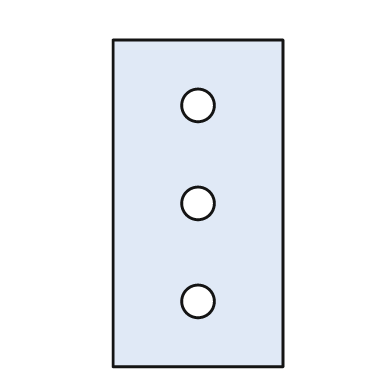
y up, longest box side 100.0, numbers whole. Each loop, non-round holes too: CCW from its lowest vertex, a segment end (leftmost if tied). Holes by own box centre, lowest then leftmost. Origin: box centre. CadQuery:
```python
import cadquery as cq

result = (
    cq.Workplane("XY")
    .moveTo(-26.0, -50.0)
    .lineTo(26.0, -50.0)
    .lineTo(26.0, 50.0)
    .lineTo(-26.0, 50.0)
    .close()
    .moveTo(0.0, -30.0)
    .circle(5.0)
    .moveTo(0.0, 0.0)
    .circle(5.0)
    .moveTo(0.0, 30.0)
    .circle(5.0)
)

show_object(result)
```